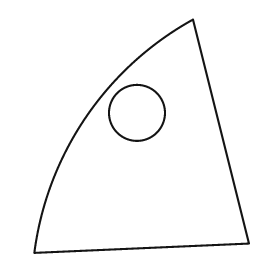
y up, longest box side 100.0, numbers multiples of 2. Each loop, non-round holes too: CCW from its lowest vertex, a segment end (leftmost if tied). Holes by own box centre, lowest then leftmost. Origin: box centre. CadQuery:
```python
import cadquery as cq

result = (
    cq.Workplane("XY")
    .moveTo(-46.0, -50.0)
    .lineTo(46.0, -46.0)
    .lineTo(22.0, 50.0)
    .threePointArc((-24.0, 8.0), (-46.0, -50.0))
    .close()
    .moveTo(-2.0, 10.0)
    .circle(12.0)
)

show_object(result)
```